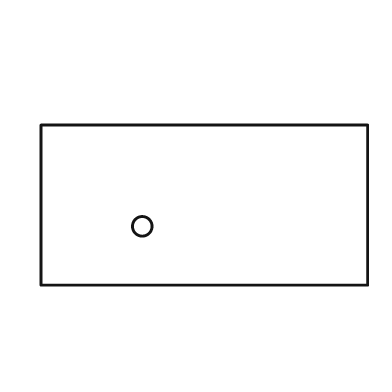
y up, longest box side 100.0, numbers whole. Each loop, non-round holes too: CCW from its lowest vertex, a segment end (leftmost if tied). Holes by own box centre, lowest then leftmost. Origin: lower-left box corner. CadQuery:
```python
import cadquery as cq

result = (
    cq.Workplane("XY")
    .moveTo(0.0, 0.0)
    .lineTo(100.0, 0.0)
    .lineTo(100.0, 49.0)
    .lineTo(0.0, 49.0)
    .close()
    .moveTo(31.0, 18.0)
    .circle(3.0)
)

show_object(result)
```